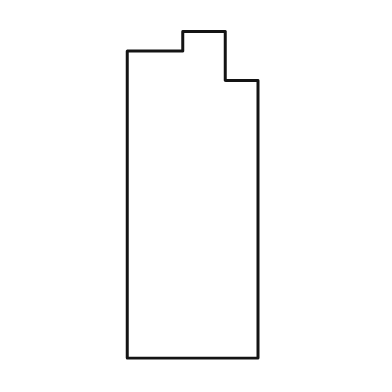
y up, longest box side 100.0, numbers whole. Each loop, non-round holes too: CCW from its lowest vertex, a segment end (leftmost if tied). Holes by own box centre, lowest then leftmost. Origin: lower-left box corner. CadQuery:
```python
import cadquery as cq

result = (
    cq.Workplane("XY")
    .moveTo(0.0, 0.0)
    .lineTo(40.0, 0.0)
    .lineTo(40.0, 85.0)
    .lineTo(30.0, 85.0)
    .lineTo(30.0, 100.0)
    .lineTo(17.0, 100.0)
    .lineTo(17.0, 94.0)
    .lineTo(0.0, 94.0)
    .close()
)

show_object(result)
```